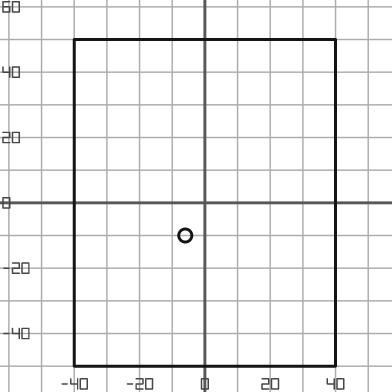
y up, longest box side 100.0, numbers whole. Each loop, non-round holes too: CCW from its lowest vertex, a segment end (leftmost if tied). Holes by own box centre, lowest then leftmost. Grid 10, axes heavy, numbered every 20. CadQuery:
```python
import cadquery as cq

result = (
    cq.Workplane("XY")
    .moveTo(-40.0, -50.0)
    .lineTo(40.0, -50.0)
    .lineTo(40.0, 50.0)
    .lineTo(-40.0, 50.0)
    .close()
    .moveTo(-6.0, -10.0)
    .circle(2.0)
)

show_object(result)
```